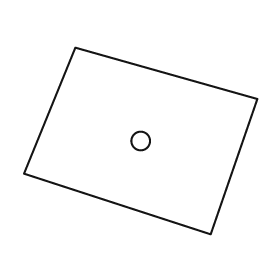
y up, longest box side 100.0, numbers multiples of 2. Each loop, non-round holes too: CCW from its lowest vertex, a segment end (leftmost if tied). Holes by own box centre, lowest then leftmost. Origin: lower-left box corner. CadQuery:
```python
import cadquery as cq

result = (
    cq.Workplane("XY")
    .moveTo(80.0, 0.0)
    .lineTo(100.0, 58.0)
    .lineTo(22.0, 80.0)
    .lineTo(0.0, 26.0)
    .close()
    .moveTo(50.0, 40.0)
    .circle(4.0)
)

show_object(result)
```